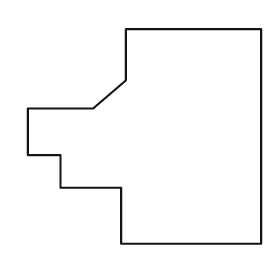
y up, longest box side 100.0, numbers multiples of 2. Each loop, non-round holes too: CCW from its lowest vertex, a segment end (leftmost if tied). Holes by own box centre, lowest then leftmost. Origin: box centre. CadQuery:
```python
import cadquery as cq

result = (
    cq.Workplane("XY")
    .moveTo(-10.0, -46.0)
    .lineTo(50.0, -46.0)
    .lineTo(50.0, 46.0)
    .lineTo(-8.0, 46.0)
    .lineTo(-8.0, 24.0)
    .lineTo(-22.0, 12.0)
    .lineTo(-50.0, 12.0)
    .lineTo(-50.0, -8.0)
    .lineTo(-36.0, -8.0)
    .lineTo(-36.0, -22.0)
    .lineTo(-10.0, -22.0)
    .close()
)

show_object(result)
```